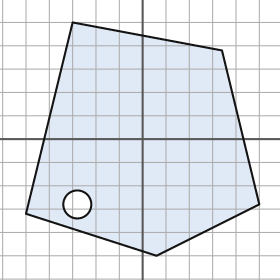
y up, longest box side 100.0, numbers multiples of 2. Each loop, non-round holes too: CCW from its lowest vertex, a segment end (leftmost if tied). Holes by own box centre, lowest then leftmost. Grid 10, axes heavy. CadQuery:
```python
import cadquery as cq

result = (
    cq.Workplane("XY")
    .moveTo(6.0, -50.0)
    .lineTo(50.0, -28.0)
    .lineTo(34.0, 38.0)
    .lineTo(-30.0, 50.0)
    .lineTo(-50.0, -32.0)
    .close()
    .moveTo(-28.0, -28.0)
    .circle(6.0)
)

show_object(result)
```